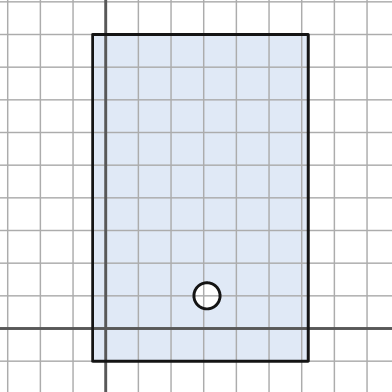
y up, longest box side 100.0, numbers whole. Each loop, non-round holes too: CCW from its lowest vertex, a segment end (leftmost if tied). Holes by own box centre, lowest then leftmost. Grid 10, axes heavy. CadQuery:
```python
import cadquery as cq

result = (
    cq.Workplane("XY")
    .moveTo(-4.0, -10.0)
    .lineTo(62.0, -10.0)
    .lineTo(62.0, 90.0)
    .lineTo(-4.0, 90.0)
    .close()
    .moveTo(31.0, 10.0)
    .circle(4.0)
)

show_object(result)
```